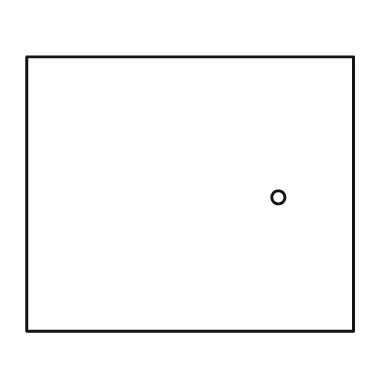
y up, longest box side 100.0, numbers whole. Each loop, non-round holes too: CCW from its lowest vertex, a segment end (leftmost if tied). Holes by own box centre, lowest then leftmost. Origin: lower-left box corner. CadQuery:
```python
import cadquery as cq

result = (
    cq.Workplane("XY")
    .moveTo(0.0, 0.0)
    .lineTo(100.0, 0.0)
    .lineTo(100.0, 84.0)
    .lineTo(0.0, 84.0)
    .close()
    .moveTo(77.0, 41.0)
    .circle(2.0)
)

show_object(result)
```